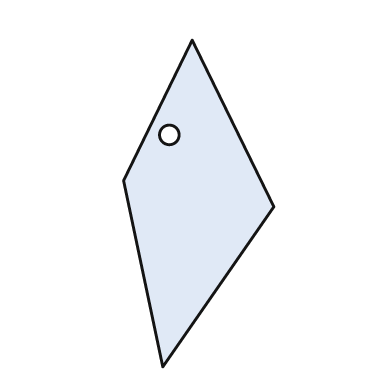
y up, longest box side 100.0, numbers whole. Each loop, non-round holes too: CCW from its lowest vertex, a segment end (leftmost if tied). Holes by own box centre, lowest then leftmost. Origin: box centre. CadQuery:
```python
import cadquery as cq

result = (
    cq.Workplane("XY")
    .moveTo(-11.0, -50.0)
    .lineTo(23.0, -1.0)
    .lineTo(-2.0, 50.0)
    .lineTo(-23.0, 7.0)
    .close()
    .moveTo(-9.0, 21.0)
    .circle(3.0)
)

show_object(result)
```